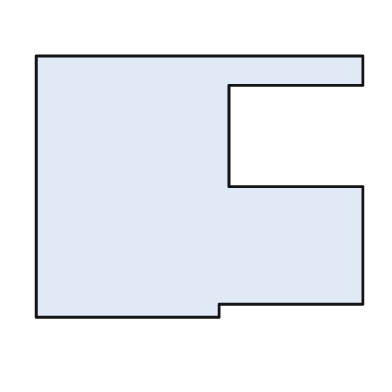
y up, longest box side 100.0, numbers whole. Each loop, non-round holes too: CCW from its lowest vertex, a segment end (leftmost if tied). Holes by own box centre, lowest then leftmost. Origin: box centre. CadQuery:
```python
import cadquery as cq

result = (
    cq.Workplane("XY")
    .moveTo(-50.0, -40.0)
    .lineTo(6.0, -40.0)
    .lineTo(6.0, -36.0)
    .lineTo(50.0, -36.0)
    .lineTo(50.0, 0.0)
    .lineTo(9.0, 0.0)
    .lineTo(9.0, 31.0)
    .lineTo(50.0, 31.0)
    .lineTo(50.0, 40.0)
    .lineTo(-50.0, 40.0)
    .close()
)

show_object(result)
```